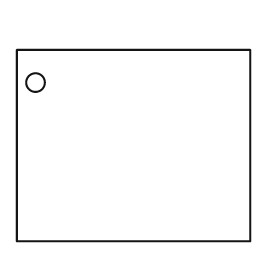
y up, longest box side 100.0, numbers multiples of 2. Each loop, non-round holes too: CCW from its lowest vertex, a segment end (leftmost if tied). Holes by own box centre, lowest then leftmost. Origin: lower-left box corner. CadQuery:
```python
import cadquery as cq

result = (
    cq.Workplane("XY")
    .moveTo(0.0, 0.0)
    .lineTo(100.0, 0.0)
    .lineTo(100.0, 82.0)
    .lineTo(0.0, 82.0)
    .close()
    .moveTo(8.0, 68.0)
    .circle(4.0)
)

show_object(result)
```